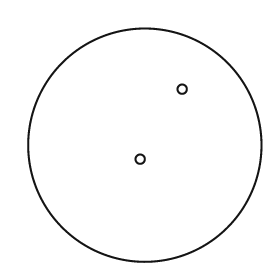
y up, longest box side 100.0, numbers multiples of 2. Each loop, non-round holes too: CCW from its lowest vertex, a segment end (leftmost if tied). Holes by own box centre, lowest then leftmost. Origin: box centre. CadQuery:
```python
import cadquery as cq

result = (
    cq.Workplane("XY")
    .moveTo(0.0, 0.0)
    .circle(50.0)
    .moveTo(-2.0, -6.0)
    .circle(2.0)
    .moveTo(16.0, 24.0)
    .circle(2.0)
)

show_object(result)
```